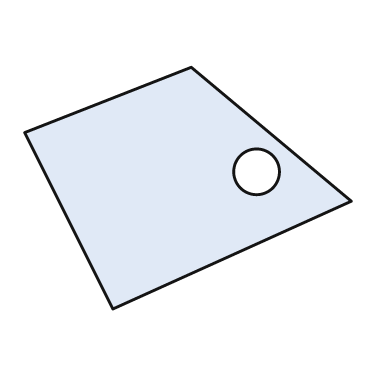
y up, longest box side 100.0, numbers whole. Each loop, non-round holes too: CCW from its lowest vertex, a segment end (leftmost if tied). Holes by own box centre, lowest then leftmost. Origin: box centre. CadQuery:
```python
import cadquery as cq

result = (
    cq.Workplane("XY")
    .moveTo(-23.0, -37.0)
    .lineTo(50.0, -4.0)
    .lineTo(1.0, 37.0)
    .lineTo(-50.0, 17.0)
    .close()
    .moveTo(21.0, 5.0)
    .circle(7.0)
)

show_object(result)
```